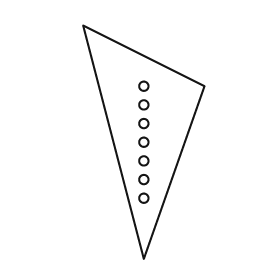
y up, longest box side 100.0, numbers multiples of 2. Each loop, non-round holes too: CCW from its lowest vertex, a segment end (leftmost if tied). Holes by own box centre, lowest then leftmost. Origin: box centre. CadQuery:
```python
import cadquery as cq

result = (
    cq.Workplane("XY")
    .moveTo(0.0, -50.0)
    .lineTo(26.0, 24.0)
    .lineTo(-26.0, 50.0)
    .close()
    .moveTo(0.0, -24.0)
    .circle(2.0)
    .moveTo(0.0, -16.0)
    .circle(2.0)
    .moveTo(0.0, -8.0)
    .circle(2.0)
    .moveTo(0.0, 0.0)
    .circle(2.0)
    .moveTo(0.0, 8.0)
    .circle(2.0)
    .moveTo(0.0, 16.0)
    .circle(2.0)
    .moveTo(0.0, 24.0)
    .circle(2.0)
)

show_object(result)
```